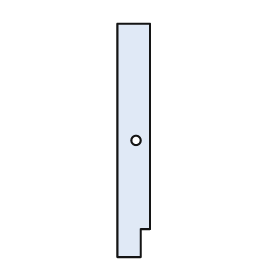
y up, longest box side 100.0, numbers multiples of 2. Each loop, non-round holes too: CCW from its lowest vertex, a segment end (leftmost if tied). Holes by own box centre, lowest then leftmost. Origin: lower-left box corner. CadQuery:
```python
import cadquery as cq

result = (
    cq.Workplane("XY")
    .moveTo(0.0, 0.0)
    .lineTo(10.0, 0.0)
    .lineTo(10.0, 12.0)
    .lineTo(14.0, 12.0)
    .lineTo(14.0, 100.0)
    .lineTo(0.0, 100.0)
    .close()
    .moveTo(8.0, 50.0)
    .circle(2.0)
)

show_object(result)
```